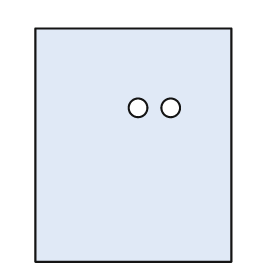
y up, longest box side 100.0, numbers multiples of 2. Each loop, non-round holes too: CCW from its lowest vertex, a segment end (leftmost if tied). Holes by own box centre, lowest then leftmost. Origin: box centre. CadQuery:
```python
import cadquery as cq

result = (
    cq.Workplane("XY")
    .moveTo(-42.0, -50.0)
    .lineTo(42.0, -50.0)
    .lineTo(42.0, 50.0)
    .lineTo(-42.0, 50.0)
    .close()
    .moveTo(2.0, 16.0)
    .circle(4.0)
    .moveTo(16.0, 16.0)
    .circle(4.0)
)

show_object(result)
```